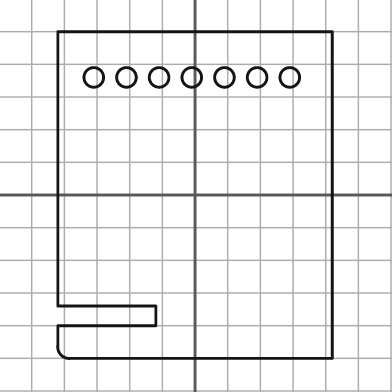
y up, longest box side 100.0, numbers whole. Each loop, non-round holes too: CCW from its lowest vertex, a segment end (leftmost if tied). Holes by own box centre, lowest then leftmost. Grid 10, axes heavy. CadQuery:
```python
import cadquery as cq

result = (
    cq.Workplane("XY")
    .moveTo(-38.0, -50.0)
    .lineTo(42.0, -50.0)
    .lineTo(42.0, 50.0)
    .lineTo(-42.0, 50.0)
    .lineTo(-42.0, -34.0)
    .lineTo(-12.0, -34.0)
    .lineTo(-12.0, -40.0)
    .lineTo(-42.0, -40.0)
    .lineTo(-42.0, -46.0)
    .threePointArc((-41.0, -49.0), (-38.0, -50.0))
    .close()
    .moveTo(-31.0, 36.0)
    .circle(3.0)
    .moveTo(-21.0, 36.0)
    .circle(3.0)
    .moveTo(-11.0, 36.0)
    .circle(3.0)
    .moveTo(-1.0, 36.0)
    .circle(3.0)
    .moveTo(9.0, 36.0)
    .circle(3.0)
    .moveTo(19.0, 36.0)
    .circle(3.0)
    .moveTo(29.0, 36.0)
    .circle(3.0)
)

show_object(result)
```